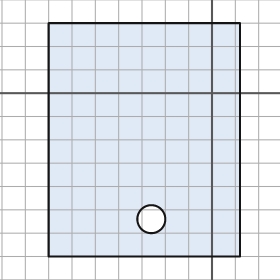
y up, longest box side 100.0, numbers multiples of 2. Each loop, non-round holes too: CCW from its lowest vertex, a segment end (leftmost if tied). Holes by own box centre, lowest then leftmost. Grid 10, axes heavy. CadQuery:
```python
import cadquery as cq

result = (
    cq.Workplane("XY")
    .moveTo(-70.0, -70.0)
    .lineTo(12.0, -70.0)
    .lineTo(12.0, 30.0)
    .lineTo(-70.0, 30.0)
    .close()
    .moveTo(-26.0, -54.0)
    .circle(6.0)
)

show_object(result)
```